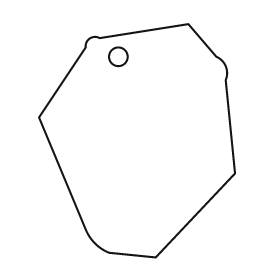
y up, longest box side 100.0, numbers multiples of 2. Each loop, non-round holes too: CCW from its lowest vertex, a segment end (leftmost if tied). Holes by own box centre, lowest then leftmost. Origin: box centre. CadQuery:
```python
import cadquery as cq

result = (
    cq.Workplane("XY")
    .moveTo(8.0, -50.0)
    .lineTo(42.0, -14.0)
    .lineTo(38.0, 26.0)
    .threePointArc((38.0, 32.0), (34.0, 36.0))
    .lineTo(22.0, 50.0)
    .lineTo(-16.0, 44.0)
    .threePointArc((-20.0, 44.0), (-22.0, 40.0))
    .lineTo(-42.0, 10.0)
    .lineTo(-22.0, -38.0)
    .threePointArc((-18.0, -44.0), (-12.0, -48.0))
    .close()
    .moveTo(-8.0, 36.0)
    .circle(4.0)
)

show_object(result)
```